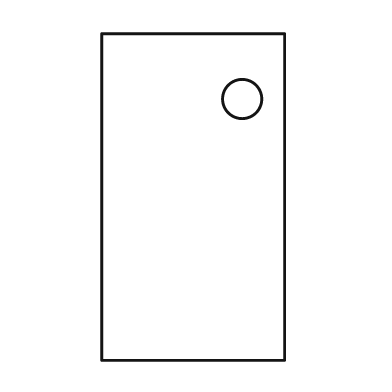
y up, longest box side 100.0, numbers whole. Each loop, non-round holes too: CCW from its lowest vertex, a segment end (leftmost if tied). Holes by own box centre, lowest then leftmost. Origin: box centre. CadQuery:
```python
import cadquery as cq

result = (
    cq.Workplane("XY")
    .moveTo(-28.0, -50.0)
    .lineTo(28.0, -50.0)
    .lineTo(28.0, 50.0)
    .lineTo(-28.0, 50.0)
    .close()
    .moveTo(15.0, 30.0)
    .circle(6.0)
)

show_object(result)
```